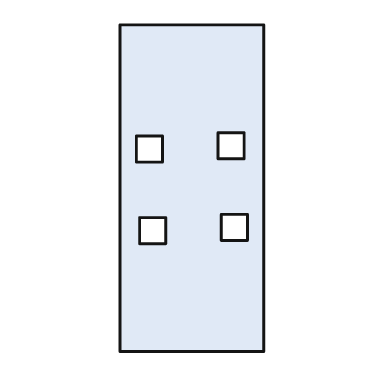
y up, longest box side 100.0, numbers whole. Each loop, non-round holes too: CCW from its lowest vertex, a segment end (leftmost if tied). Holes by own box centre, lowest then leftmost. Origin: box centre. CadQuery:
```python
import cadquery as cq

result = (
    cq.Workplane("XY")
    .moveTo(-22.0, -50.0)
    .lineTo(22.0, -50.0)
    .lineTo(22.0, 50.0)
    .lineTo(-22.0, 50.0)
    .close()
    .moveTo(-16.0, -17.0)
    .lineTo(-8.0, -17.0)
    .lineTo(-8.0, -9.0)
    .lineTo(-16.0, -9.0)
    .close()
    .moveTo(9.0, -16.0)
    .lineTo(17.0, -16.0)
    .lineTo(17.0, -8.0)
    .lineTo(9.0, -8.0)
    .close()
    .moveTo(-17.0, 8.0)
    .lineTo(-9.0, 8.0)
    .lineTo(-9.0, 16.0)
    .lineTo(-17.0, 16.0)
    .close()
    .moveTo(8.0, 9.0)
    .lineTo(16.0, 9.0)
    .lineTo(16.0, 17.0)
    .lineTo(8.0, 17.0)
    .close()
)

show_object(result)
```